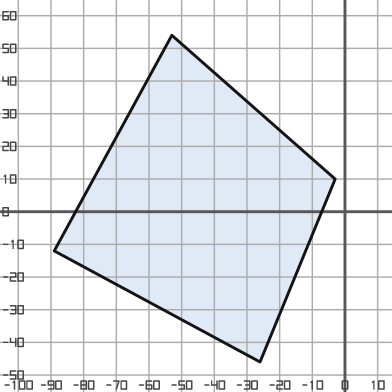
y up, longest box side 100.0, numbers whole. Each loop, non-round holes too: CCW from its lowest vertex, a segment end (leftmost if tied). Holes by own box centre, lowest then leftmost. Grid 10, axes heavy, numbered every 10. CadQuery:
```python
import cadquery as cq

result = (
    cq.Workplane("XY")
    .moveTo(-26.0, -46.0)
    .lineTo(-3.0, 10.0)
    .lineTo(-53.0, 54.0)
    .lineTo(-89.0, -12.0)
    .close()
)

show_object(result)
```